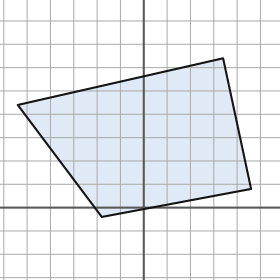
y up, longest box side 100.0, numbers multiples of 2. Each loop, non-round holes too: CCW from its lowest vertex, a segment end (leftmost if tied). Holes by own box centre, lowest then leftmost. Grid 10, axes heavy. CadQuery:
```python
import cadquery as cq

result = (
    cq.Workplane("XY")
    .moveTo(-18.0, -4.0)
    .lineTo(46.0, 8.0)
    .lineTo(34.0, 64.0)
    .lineTo(-54.0, 44.0)
    .close()
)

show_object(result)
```